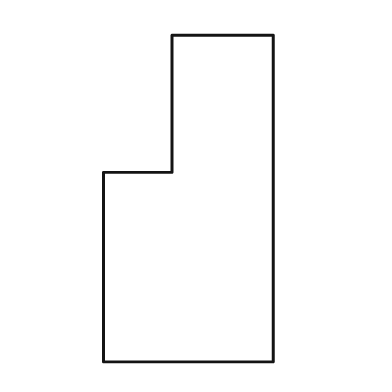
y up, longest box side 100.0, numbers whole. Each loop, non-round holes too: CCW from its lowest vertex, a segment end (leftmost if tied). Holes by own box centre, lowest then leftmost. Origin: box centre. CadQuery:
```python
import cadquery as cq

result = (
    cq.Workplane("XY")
    .moveTo(-26.0, -50.0)
    .lineTo(26.0, -50.0)
    .lineTo(26.0, 50.0)
    .lineTo(-5.0, 50.0)
    .lineTo(-5.0, 8.0)
    .lineTo(-26.0, 8.0)
    .close()
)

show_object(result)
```